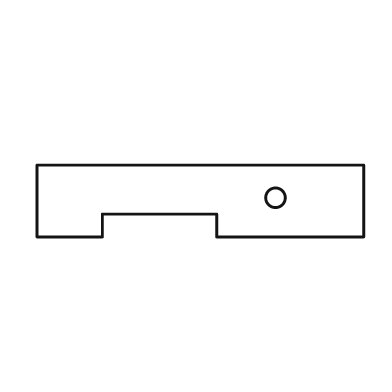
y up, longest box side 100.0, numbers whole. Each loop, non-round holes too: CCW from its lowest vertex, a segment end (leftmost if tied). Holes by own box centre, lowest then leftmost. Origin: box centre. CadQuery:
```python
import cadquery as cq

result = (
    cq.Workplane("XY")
    .moveTo(-50.0, -11.0)
    .lineTo(-30.0, -11.0)
    .lineTo(-30.0, -4.0)
    .lineTo(5.0, -4.0)
    .lineTo(5.0, -11.0)
    .lineTo(50.0, -11.0)
    .lineTo(50.0, 11.0)
    .lineTo(-50.0, 11.0)
    .close()
    .moveTo(23.0, 1.0)
    .circle(3.0)
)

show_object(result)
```